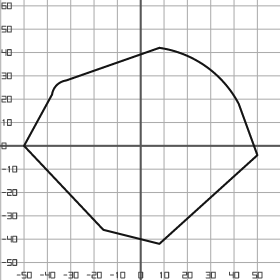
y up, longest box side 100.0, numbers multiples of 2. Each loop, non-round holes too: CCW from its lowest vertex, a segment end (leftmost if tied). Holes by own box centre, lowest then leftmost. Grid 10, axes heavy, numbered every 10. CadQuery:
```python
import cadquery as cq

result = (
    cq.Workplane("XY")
    .moveTo(8.0, -42.0)
    .lineTo(50.0, -4.0)
    .lineTo(42.0, 18.0)
    .threePointArc((28.0, 34.0), (8.0, 42.0))
    .lineTo(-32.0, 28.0)
    .threePointArc((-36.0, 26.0), (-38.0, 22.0))
    .lineTo(-50.0, 0.0)
    .lineTo(-16.0, -36.0)
    .close()
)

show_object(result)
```